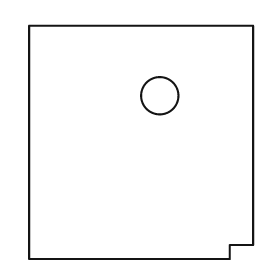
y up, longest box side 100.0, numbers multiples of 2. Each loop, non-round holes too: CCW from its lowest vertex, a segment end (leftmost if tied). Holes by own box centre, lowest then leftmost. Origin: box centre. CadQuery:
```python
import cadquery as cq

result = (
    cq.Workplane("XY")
    .moveTo(-48.0, -50.0)
    .lineTo(38.0, -50.0)
    .lineTo(38.0, -44.0)
    .lineTo(48.0, -44.0)
    .lineTo(48.0, 50.0)
    .lineTo(-48.0, 50.0)
    .close()
    .moveTo(8.0, 20.0)
    .circle(8.0)
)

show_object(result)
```